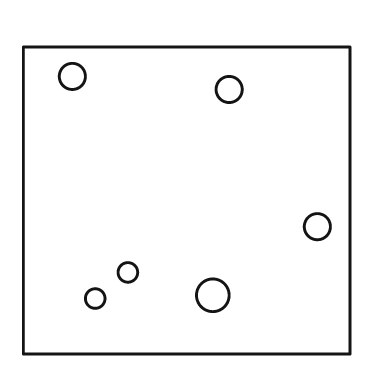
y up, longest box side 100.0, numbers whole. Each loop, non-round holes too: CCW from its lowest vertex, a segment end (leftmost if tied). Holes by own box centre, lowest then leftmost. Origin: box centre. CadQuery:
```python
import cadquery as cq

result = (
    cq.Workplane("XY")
    .moveTo(-50.0, -47.0)
    .lineTo(50.0, -47.0)
    .lineTo(50.0, 47.0)
    .lineTo(-50.0, 47.0)
    .close()
    .moveTo(-28.0, -30.0)
    .circle(3.0)
    .moveTo(8.0, -29.0)
    .circle(5.0)
    .moveTo(-18.0, -22.0)
    .circle(3.0)
    .moveTo(40.0, -8.0)
    .circle(4.0)
    .moveTo(13.0, 34.0)
    .circle(4.0)
    .moveTo(-35.0, 38.0)
    .circle(4.0)
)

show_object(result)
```